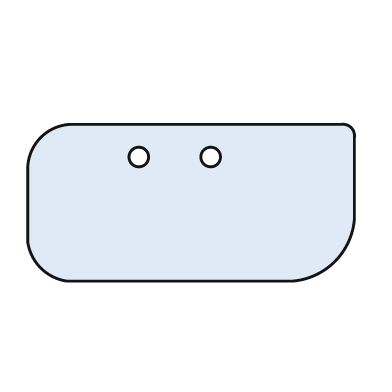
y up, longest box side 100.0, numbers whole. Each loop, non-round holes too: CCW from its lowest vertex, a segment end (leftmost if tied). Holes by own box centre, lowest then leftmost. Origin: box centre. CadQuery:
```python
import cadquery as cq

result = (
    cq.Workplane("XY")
    .moveTo(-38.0, -24.0)
    .lineTo(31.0, -24.0)
    .threePointArc((44.0, -18.0), (50.0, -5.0))
    .lineTo(50.0, 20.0)
    .threePointArc((49.0, 23.0), (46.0, 24.0))
    .lineTo(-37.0, 24.0)
    .threePointArc((-46.0, 20.0), (-50.0, 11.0))
    .lineTo(-50.0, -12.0)
    .threePointArc((-46.0, -20.0), (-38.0, -24.0))
    .close()
    .moveTo(-16.0, 14.0)
    .circle(3.0)
    .moveTo(6.0, 14.0)
    .circle(3.0)
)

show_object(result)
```